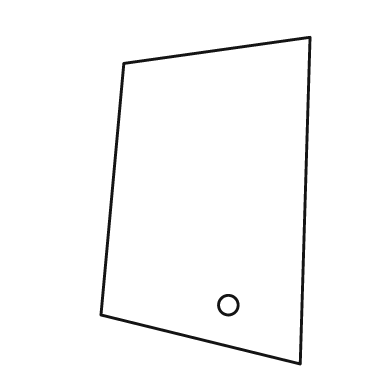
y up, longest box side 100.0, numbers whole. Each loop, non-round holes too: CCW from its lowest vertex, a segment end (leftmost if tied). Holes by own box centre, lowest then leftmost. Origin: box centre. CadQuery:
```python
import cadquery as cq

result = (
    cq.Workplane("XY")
    .moveTo(29.0, -50.0)
    .lineTo(32.0, 50.0)
    .lineTo(-25.0, 42.0)
    .lineTo(-32.0, -35.0)
    .close()
    .moveTo(7.0, -32.0)
    .circle(3.0)
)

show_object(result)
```